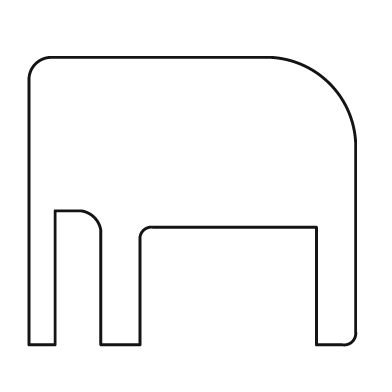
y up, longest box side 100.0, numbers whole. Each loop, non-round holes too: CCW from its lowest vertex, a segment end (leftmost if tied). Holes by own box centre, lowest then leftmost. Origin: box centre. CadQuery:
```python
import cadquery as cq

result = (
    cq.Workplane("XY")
    .moveTo(-50.0, -44.0)
    .lineTo(-42.0, -44.0)
    .lineTo(-42.0, -3.0)
    .lineTo(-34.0, -3.0)
    .threePointArc((-30.0, -5.0), (-28.0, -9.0))
    .lineTo(-28.0, -44.0)
    .lineTo(-16.0, -44.0)
    .lineTo(-16.0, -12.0)
    .threePointArc((-15.0, -9.0), (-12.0, -8.0))
    .lineTo(38.0, -8.0)
    .lineTo(38.0, -44.0)
    .lineTo(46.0, -44.0)
    .threePointArc((49.0, -43.0), (50.0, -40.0))
    .lineTo(50.0, 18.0)
    .threePointArc((42.0, 36.0), (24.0, 44.0))
    .lineTo(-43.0, 44.0)
    .threePointArc((-48.0, 42.0), (-50.0, 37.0))
    .close()
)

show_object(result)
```